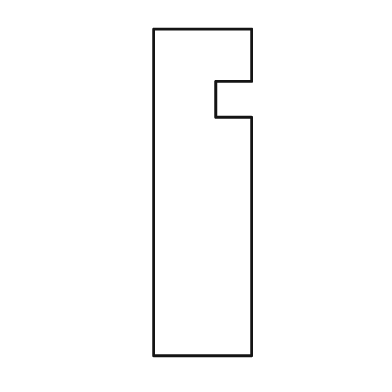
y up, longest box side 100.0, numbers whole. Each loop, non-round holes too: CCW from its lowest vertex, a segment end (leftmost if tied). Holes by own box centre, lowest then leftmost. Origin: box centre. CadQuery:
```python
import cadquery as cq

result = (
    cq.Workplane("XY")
    .moveTo(-15.0, -50.0)
    .lineTo(15.0, -50.0)
    .lineTo(15.0, 23.0)
    .lineTo(4.0, 23.0)
    .lineTo(4.0, 34.0)
    .lineTo(15.0, 34.0)
    .lineTo(15.0, 50.0)
    .lineTo(-15.0, 50.0)
    .close()
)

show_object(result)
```